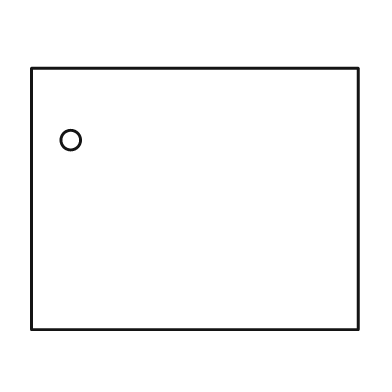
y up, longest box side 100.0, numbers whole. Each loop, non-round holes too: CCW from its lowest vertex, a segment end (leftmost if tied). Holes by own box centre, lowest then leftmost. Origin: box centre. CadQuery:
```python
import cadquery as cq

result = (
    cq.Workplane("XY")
    .moveTo(-50.0, -40.0)
    .lineTo(50.0, -40.0)
    .lineTo(50.0, 40.0)
    .lineTo(-50.0, 40.0)
    .close()
    .moveTo(-38.0, 18.0)
    .circle(3.0)
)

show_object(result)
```